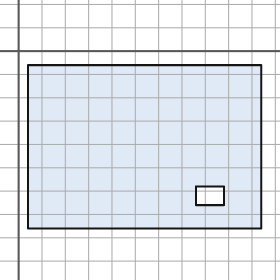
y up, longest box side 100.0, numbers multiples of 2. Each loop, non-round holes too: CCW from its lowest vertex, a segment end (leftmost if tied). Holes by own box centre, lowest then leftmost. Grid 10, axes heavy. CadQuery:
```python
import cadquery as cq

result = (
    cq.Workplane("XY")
    .moveTo(4.0, -76.0)
    .lineTo(104.0, -76.0)
    .lineTo(104.0, -6.0)
    .lineTo(4.0, -6.0)
    .close()
    .moveTo(76.0, -66.0)
    .lineTo(88.0, -66.0)
    .lineTo(88.0, -58.0)
    .lineTo(76.0, -58.0)
    .close()
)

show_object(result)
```